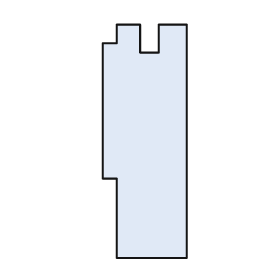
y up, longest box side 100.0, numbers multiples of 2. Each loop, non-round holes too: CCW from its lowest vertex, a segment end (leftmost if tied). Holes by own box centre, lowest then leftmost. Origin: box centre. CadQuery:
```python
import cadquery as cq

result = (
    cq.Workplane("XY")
    .moveTo(-12.0, -50.0)
    .lineTo(18.0, -50.0)
    .lineTo(18.0, 50.0)
    .lineTo(6.0, 50.0)
    .lineTo(6.0, 38.0)
    .lineTo(-2.0, 38.0)
    .lineTo(-2.0, 50.0)
    .lineTo(-12.0, 50.0)
    .lineTo(-12.0, 42.0)
    .lineTo(-18.0, 42.0)
    .lineTo(-18.0, -16.0)
    .lineTo(-12.0, -16.0)
    .close()
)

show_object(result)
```